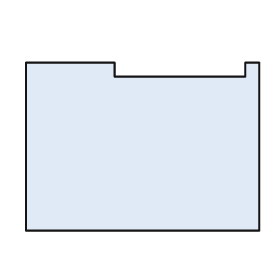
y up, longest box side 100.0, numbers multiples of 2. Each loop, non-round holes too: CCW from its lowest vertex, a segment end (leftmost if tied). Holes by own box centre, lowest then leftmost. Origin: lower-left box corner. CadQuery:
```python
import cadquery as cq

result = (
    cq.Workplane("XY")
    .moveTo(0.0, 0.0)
    .lineTo(100.0, 0.0)
    .lineTo(100.0, 72.0)
    .lineTo(94.0, 72.0)
    .lineTo(94.0, 66.0)
    .lineTo(38.0, 66.0)
    .lineTo(38.0, 72.0)
    .lineTo(0.0, 72.0)
    .close()
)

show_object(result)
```